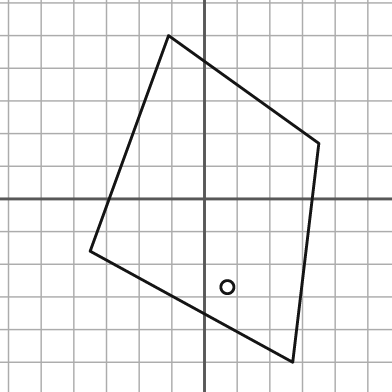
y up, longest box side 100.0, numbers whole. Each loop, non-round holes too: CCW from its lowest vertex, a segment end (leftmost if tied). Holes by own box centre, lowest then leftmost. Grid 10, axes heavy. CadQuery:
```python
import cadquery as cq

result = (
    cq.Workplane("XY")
    .moveTo(27.0, -50.0)
    .lineTo(35.0, 17.0)
    .lineTo(-11.0, 50.0)
    .lineTo(-35.0, -16.0)
    .close()
    .moveTo(7.0, -27.0)
    .circle(2.0)
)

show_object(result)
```